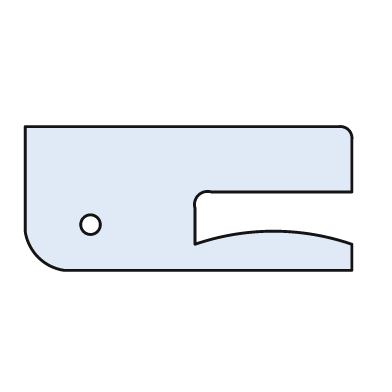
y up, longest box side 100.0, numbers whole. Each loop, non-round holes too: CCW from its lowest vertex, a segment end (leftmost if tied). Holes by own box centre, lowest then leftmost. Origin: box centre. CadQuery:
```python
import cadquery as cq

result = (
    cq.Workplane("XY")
    .moveTo(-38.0, -22.0)
    .lineTo(50.0, -22.0)
    .lineTo(50.0, -14.0)
    .threePointArc((26.0, -10.0), (2.0, -14.0))
    .lineTo(2.0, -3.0)
    .threePointArc((3.0, 1.0), (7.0, 2.0))
    .lineTo(50.0, 2.0)
    .lineTo(50.0, 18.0)
    .threePointArc((49.0, 21.0), (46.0, 22.0))
    .lineTo(-50.0, 22.0)
    .lineTo(-50.0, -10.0)
    .threePointArc((-46.0, -18.0), (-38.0, -22.0))
    .close()
    .moveTo(-30.0, -8.0)
    .circle(3.0)
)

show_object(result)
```